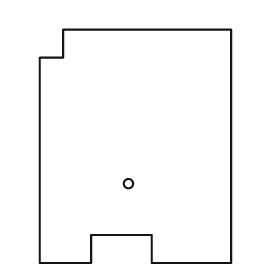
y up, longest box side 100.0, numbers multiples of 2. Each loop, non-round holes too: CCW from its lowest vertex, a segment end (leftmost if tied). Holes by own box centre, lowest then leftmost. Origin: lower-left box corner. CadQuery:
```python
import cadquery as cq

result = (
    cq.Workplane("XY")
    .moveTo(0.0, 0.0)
    .lineTo(22.0, 0.0)
    .lineTo(22.0, 12.0)
    .lineTo(48.0, 12.0)
    .lineTo(48.0, 0.0)
    .lineTo(82.0, 0.0)
    .lineTo(82.0, 100.0)
    .lineTo(10.0, 100.0)
    .lineTo(10.0, 88.0)
    .lineTo(0.0, 88.0)
    .close()
    .moveTo(38.0, 34.0)
    .circle(2.0)
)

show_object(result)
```